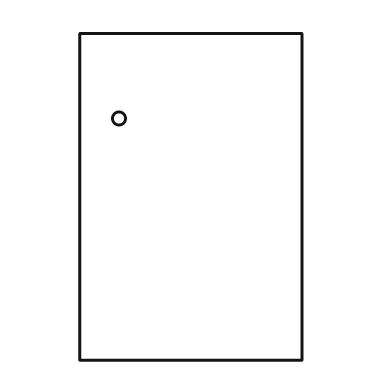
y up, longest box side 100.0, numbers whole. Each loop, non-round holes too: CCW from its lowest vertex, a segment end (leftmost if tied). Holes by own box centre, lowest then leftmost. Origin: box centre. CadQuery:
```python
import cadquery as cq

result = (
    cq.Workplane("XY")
    .moveTo(-34.0, -50.0)
    .lineTo(34.0, -50.0)
    .lineTo(34.0, 50.0)
    .lineTo(-34.0, 50.0)
    .close()
    .moveTo(-22.0, 24.0)
    .circle(2.0)
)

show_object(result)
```